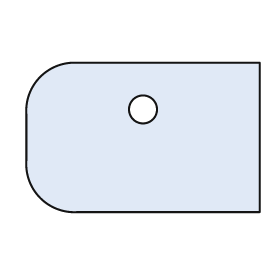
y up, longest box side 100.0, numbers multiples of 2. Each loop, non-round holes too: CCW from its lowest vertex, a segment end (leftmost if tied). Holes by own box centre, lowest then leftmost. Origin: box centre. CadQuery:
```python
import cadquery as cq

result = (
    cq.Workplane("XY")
    .moveTo(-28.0, -32.0)
    .lineTo(50.0, -32.0)
    .lineTo(50.0, 32.0)
    .lineTo(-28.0, 32.0)
    .threePointArc((-44.0, 26.0), (-50.0, 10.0))
    .lineTo(-50.0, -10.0)
    .threePointArc((-44.0, -26.0), (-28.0, -32.0))
    .close()
    .moveTo(0.0, 12.0)
    .circle(6.0)
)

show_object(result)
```